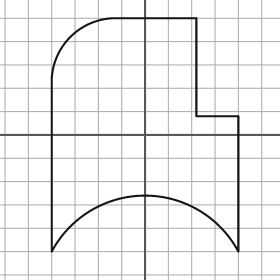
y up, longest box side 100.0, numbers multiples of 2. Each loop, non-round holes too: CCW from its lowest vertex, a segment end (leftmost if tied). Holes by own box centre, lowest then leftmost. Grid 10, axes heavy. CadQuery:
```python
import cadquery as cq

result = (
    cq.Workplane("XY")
    .moveTo(-40.0, -50.0)
    .threePointArc((0.0, -26.0), (40.0, -50.0))
    .lineTo(40.0, 8.0)
    .lineTo(22.0, 8.0)
    .lineTo(22.0, 50.0)
    .lineTo(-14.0, 50.0)
    .threePointArc((-32.0, 42.0), (-40.0, 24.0))
    .close()
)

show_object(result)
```